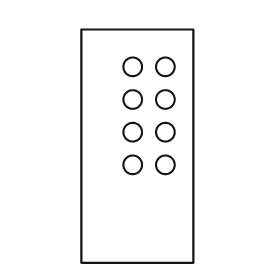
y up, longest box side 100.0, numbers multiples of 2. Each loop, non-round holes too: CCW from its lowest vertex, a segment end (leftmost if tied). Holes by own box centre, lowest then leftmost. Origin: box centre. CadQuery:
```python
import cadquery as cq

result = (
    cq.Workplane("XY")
    .moveTo(-24.0, -50.0)
    .lineTo(24.0, -50.0)
    .lineTo(24.0, 50.0)
    .lineTo(-24.0, 50.0)
    .close()
    .moveTo(-2.0, -8.0)
    .circle(4.0)
    .moveTo(12.0, -8.0)
    .circle(4.0)
    .moveTo(-2.0, 6.0)
    .circle(4.0)
    .moveTo(12.0, 6.0)
    .circle(4.0)
    .moveTo(-2.0, 20.0)
    .circle(4.0)
    .moveTo(12.0, 20.0)
    .circle(4.0)
    .moveTo(-2.0, 34.0)
    .circle(4.0)
    .moveTo(12.0, 34.0)
    .circle(4.0)
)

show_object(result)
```